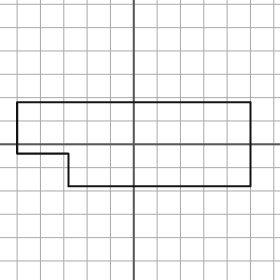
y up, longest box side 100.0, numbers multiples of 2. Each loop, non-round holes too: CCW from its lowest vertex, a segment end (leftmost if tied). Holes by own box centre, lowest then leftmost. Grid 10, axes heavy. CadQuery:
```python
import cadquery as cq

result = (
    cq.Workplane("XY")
    .moveTo(-28.0, -18.0)
    .lineTo(50.0, -18.0)
    .lineTo(50.0, 18.0)
    .lineTo(-50.0, 18.0)
    .lineTo(-50.0, -4.0)
    .lineTo(-28.0, -4.0)
    .close()
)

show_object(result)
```